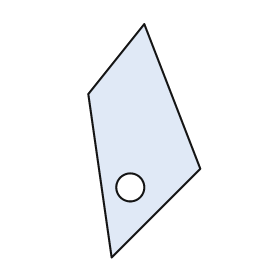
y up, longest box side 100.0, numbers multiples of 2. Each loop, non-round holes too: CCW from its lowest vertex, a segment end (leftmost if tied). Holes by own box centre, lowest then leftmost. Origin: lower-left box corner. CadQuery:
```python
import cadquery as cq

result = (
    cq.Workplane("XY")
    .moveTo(10.0, 0.0)
    .lineTo(48.0, 38.0)
    .lineTo(24.0, 100.0)
    .lineTo(0.0, 70.0)
    .close()
    .moveTo(18.0, 30.0)
    .circle(6.0)
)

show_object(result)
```